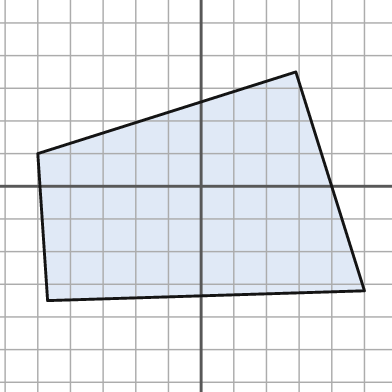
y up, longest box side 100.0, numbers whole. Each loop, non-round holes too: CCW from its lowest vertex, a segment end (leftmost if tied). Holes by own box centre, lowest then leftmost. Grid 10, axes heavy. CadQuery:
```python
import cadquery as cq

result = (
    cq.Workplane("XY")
    .moveTo(-47.0, -35.0)
    .lineTo(50.0, -32.0)
    .lineTo(29.0, 35.0)
    .lineTo(-50.0, 10.0)
    .close()
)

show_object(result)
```